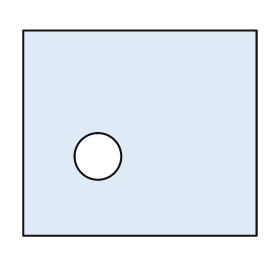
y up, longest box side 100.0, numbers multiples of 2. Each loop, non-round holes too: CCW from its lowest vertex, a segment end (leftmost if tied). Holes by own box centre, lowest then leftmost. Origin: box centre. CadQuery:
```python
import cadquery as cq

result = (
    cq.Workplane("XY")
    .moveTo(-50.0, -44.0)
    .lineTo(50.0, -44.0)
    .lineTo(50.0, 44.0)
    .lineTo(-50.0, 44.0)
    .close()
    .moveTo(-18.0, -10.0)
    .circle(10.0)
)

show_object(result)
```